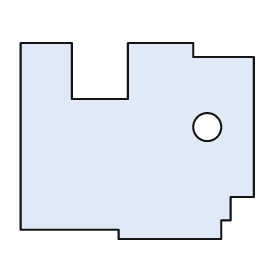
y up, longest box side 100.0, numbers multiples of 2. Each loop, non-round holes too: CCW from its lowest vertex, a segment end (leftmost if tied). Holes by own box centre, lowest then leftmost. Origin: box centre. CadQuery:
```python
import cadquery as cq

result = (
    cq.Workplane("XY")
    .moveTo(-8.0, -42.0)
    .lineTo(36.0, -42.0)
    .lineTo(36.0, -34.0)
    .lineTo(40.0, -34.0)
    .lineTo(40.0, -24.0)
    .lineTo(50.0, -24.0)
    .lineTo(50.0, 36.0)
    .lineTo(24.0, 36.0)
    .lineTo(24.0, 42.0)
    .lineTo(-4.0, 42.0)
    .lineTo(-4.0, 18.0)
    .lineTo(-28.0, 18.0)
    .lineTo(-28.0, 42.0)
    .lineTo(-50.0, 42.0)
    .lineTo(-50.0, -38.0)
    .lineTo(-8.0, -38.0)
    .close()
    .moveTo(30.0, 6.0)
    .circle(6.0)
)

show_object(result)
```